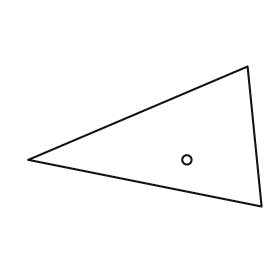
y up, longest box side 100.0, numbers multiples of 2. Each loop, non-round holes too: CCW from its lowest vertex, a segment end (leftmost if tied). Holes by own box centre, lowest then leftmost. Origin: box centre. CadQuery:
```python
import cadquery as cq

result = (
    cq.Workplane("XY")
    .moveTo(50.0, -30.0)
    .lineTo(44.0, 30.0)
    .lineTo(-50.0, -10.0)
    .close()
    .moveTo(18.0, -10.0)
    .circle(2.0)
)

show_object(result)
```